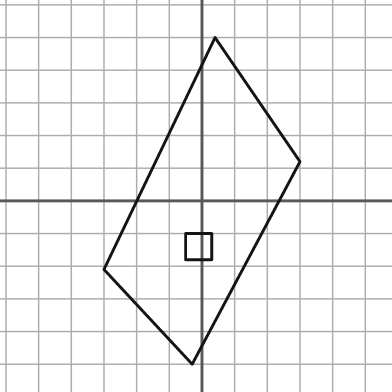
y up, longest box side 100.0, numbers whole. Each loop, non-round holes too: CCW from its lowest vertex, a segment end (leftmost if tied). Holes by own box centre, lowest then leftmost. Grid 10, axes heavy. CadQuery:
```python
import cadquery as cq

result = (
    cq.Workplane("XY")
    .moveTo(-3.0, -50.0)
    .lineTo(30.0, 12.0)
    .lineTo(4.0, 50.0)
    .lineTo(-30.0, -21.0)
    .close()
    .moveTo(-5.0, -18.0)
    .lineTo(3.0, -18.0)
    .lineTo(3.0, -10.0)
    .lineTo(-5.0, -10.0)
    .close()
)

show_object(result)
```